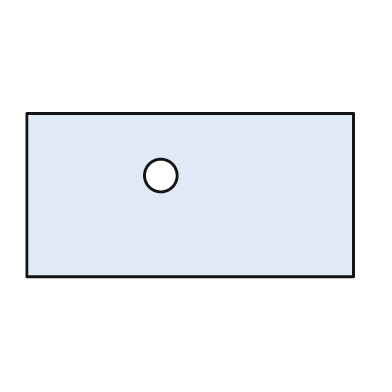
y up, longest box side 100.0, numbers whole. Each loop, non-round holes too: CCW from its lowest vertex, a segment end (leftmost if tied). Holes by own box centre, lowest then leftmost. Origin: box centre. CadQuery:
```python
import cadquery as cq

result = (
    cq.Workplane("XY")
    .moveTo(-50.0, -25.0)
    .lineTo(50.0, -25.0)
    .lineTo(50.0, 25.0)
    .lineTo(-50.0, 25.0)
    .close()
    .moveTo(-9.0, 6.0)
    .circle(5.0)
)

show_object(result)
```